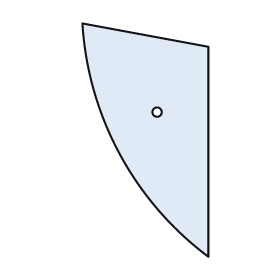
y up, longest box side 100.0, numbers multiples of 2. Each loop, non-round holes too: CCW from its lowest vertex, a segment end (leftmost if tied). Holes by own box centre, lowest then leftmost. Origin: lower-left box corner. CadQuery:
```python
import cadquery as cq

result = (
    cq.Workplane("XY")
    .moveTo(54.0, 0.0)
    .lineTo(54.0, 90.0)
    .lineTo(0.0, 100.0)
    .threePointArc((16.0, 44.0), (54.0, 0.0))
    .close()
    .moveTo(32.0, 62.0)
    .circle(2.0)
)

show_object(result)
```